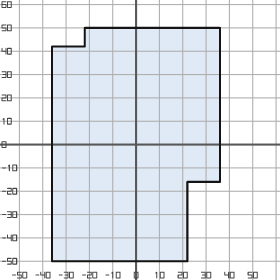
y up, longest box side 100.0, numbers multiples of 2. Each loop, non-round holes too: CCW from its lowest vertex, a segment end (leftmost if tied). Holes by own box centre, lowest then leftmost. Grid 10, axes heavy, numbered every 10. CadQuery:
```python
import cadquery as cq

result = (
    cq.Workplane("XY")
    .moveTo(-36.0, -50.0)
    .lineTo(22.0, -50.0)
    .lineTo(22.0, -16.0)
    .lineTo(36.0, -16.0)
    .lineTo(36.0, 50.0)
    .lineTo(-22.0, 50.0)
    .lineTo(-22.0, 42.0)
    .lineTo(-36.0, 42.0)
    .close()
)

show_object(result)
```